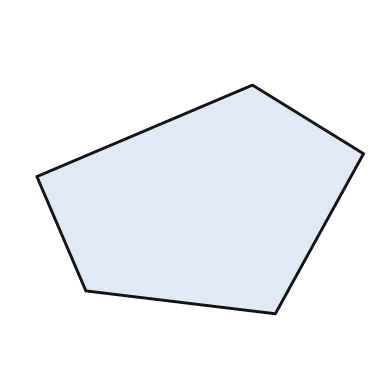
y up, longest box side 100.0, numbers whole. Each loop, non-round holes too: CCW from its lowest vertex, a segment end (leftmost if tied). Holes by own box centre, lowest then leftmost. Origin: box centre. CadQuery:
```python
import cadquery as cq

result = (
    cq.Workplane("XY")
    .moveTo(23.0, -35.0)
    .lineTo(50.0, 14.0)
    .lineTo(16.0, 35.0)
    .lineTo(-50.0, 7.0)
    .lineTo(-35.0, -28.0)
    .close()
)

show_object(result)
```